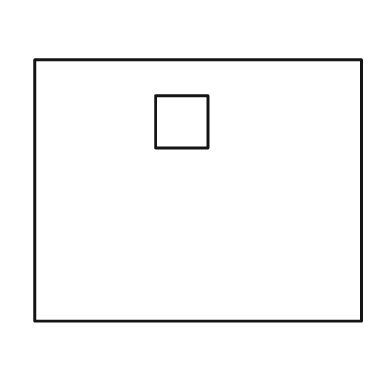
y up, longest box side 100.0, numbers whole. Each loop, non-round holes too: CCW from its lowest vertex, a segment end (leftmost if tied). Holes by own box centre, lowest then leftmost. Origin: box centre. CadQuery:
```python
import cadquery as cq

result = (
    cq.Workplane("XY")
    .moveTo(-50.0, -40.0)
    .lineTo(50.0, -40.0)
    .lineTo(50.0, 40.0)
    .lineTo(-50.0, 40.0)
    .close()
    .moveTo(-13.0, 13.0)
    .lineTo(3.0, 13.0)
    .lineTo(3.0, 29.0)
    .lineTo(-13.0, 29.0)
    .close()
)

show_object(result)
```